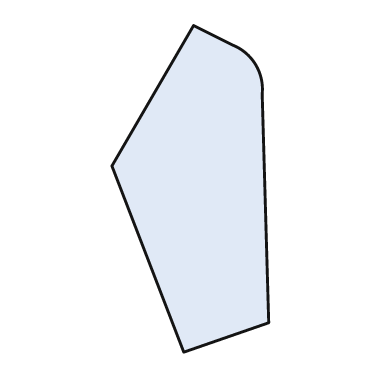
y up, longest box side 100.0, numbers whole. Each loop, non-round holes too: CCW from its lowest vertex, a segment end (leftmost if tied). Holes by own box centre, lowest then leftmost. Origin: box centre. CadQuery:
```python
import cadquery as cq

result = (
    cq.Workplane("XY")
    .moveTo(-2.0, -50.0)
    .lineTo(24.0, -41.0)
    .lineTo(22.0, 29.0)
    .threePointArc((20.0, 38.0), (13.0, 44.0))
    .lineTo(1.0, 50.0)
    .lineTo(-24.0, 7.0)
    .close()
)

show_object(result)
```